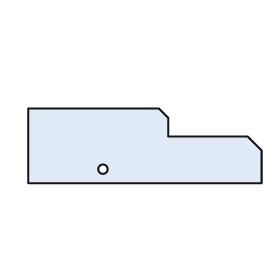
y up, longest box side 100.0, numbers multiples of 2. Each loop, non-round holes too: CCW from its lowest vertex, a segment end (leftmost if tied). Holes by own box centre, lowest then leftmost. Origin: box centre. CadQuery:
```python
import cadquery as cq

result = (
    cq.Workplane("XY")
    .moveTo(-50.0, -16.0)
    .lineTo(50.0, -16.0)
    .lineTo(50.0, -2.0)
    .lineTo(44.0, 4.0)
    .lineTo(10.0, 4.0)
    .lineTo(10.0, 12.0)
    .lineTo(6.0, 16.0)
    .lineTo(-50.0, 16.0)
    .close()
    .moveTo(-18.0, -10.0)
    .circle(2.0)
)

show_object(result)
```